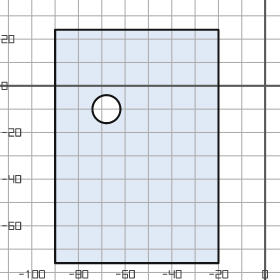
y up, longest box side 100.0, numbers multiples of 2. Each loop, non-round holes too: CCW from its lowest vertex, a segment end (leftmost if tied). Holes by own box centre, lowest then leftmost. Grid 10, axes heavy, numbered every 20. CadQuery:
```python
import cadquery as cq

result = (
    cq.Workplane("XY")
    .moveTo(-90.0, -76.0)
    .lineTo(-20.0, -76.0)
    .lineTo(-20.0, 24.0)
    .lineTo(-90.0, 24.0)
    .close()
    .moveTo(-68.0, -10.0)
    .circle(6.0)
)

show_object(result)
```